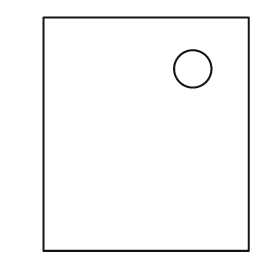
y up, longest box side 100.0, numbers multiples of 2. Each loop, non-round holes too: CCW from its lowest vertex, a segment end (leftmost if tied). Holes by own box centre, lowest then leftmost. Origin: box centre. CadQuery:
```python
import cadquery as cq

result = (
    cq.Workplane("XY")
    .moveTo(-44.0, -50.0)
    .lineTo(44.0, -50.0)
    .lineTo(44.0, 50.0)
    .lineTo(-44.0, 50.0)
    .close()
    .moveTo(20.0, 28.0)
    .circle(8.0)
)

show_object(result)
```